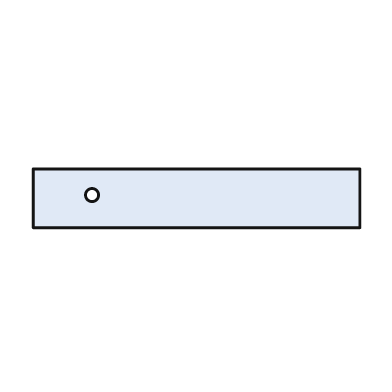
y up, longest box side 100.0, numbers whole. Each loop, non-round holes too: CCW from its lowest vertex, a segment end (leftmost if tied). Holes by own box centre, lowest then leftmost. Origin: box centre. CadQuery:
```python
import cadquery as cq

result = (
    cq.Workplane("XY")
    .moveTo(-50.0, -9.0)
    .lineTo(50.0, -9.0)
    .lineTo(50.0, 9.0)
    .lineTo(-50.0, 9.0)
    .close()
    .moveTo(-32.0, 1.0)
    .circle(2.0)
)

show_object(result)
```